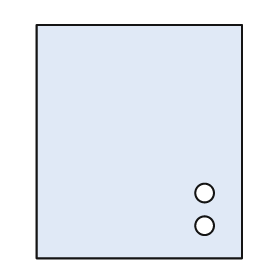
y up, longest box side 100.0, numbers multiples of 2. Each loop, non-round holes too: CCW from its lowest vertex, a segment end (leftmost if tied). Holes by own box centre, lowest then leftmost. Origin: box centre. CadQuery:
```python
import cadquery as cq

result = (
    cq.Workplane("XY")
    .moveTo(-44.0, -50.0)
    .lineTo(44.0, -50.0)
    .lineTo(44.0, 50.0)
    .lineTo(-44.0, 50.0)
    .close()
    .moveTo(28.0, -36.0)
    .circle(4.0)
    .moveTo(28.0, -22.0)
    .circle(4.0)
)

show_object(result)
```